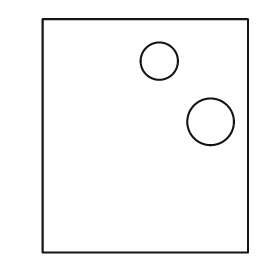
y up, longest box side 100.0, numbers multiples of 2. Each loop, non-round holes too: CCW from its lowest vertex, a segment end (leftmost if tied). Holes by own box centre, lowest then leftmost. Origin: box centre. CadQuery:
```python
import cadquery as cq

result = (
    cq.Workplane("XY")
    .moveTo(-44.0, -50.0)
    .lineTo(44.0, -50.0)
    .lineTo(44.0, 50.0)
    .lineTo(-44.0, 50.0)
    .close()
    .moveTo(28.0, 6.0)
    .circle(10.0)
    .moveTo(6.0, 32.0)
    .circle(8.0)
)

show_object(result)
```